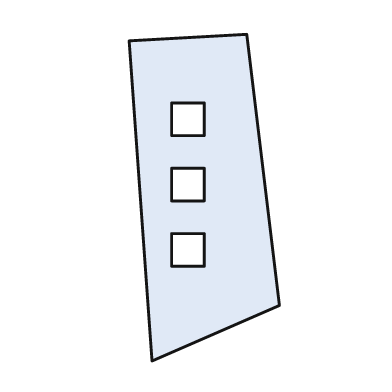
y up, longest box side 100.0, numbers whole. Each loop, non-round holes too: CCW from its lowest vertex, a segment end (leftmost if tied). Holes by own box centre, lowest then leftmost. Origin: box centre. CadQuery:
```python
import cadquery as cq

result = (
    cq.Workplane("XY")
    .moveTo(-16.0, -50.0)
    .lineTo(23.0, -33.0)
    .lineTo(13.0, 50.0)
    .lineTo(-23.0, 48.0)
    .close()
    .moveTo(-10.0, -21.0)
    .lineTo(0.0, -21.0)
    .lineTo(0.0, -11.0)
    .lineTo(-10.0, -11.0)
    .close()
    .moveTo(-10.0, -1.0)
    .lineTo(0.0, -1.0)
    .lineTo(0.0, 9.0)
    .lineTo(-10.0, 9.0)
    .close()
    .moveTo(-10.0, 19.0)
    .lineTo(0.0, 19.0)
    .lineTo(0.0, 29.0)
    .lineTo(-10.0, 29.0)
    .close()
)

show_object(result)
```